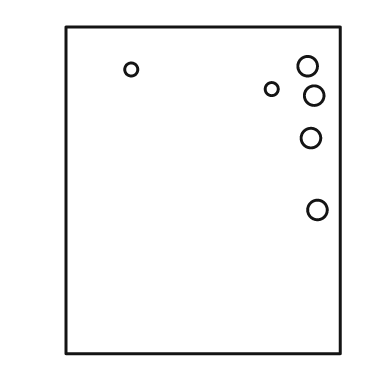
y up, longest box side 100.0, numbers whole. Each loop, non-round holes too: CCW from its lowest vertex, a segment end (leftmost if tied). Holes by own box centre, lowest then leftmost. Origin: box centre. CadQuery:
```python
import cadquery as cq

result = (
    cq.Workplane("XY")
    .moveTo(-42.0, -50.0)
    .lineTo(42.0, -50.0)
    .lineTo(42.0, 50.0)
    .lineTo(-42.0, 50.0)
    .close()
    .moveTo(35.0, -6.0)
    .circle(3.0)
    .moveTo(33.0, 16.0)
    .circle(3.0)
    .moveTo(34.0, 29.0)
    .circle(3.0)
    .moveTo(21.0, 31.0)
    .circle(2.0)
    .moveTo(-22.0, 37.0)
    .circle(2.0)
    .moveTo(32.0, 38.0)
    .circle(3.0)
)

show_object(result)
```